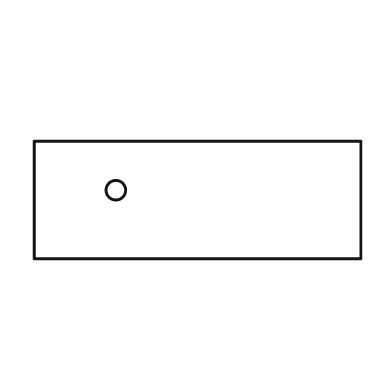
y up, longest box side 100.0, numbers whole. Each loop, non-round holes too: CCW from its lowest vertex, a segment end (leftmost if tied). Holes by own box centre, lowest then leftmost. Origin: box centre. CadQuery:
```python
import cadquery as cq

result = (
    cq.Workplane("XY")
    .moveTo(-50.0, -18.0)
    .lineTo(50.0, -18.0)
    .lineTo(50.0, 18.0)
    .lineTo(-50.0, 18.0)
    .close()
    .moveTo(-25.0, 3.0)
    .circle(3.0)
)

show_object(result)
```